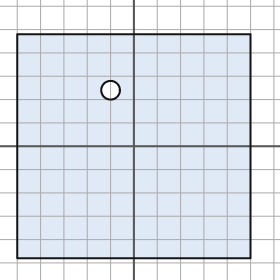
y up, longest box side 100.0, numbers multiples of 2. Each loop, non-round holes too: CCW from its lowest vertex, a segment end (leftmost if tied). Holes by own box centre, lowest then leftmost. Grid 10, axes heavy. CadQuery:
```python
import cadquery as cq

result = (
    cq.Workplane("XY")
    .moveTo(-50.0, -48.0)
    .lineTo(50.0, -48.0)
    .lineTo(50.0, 48.0)
    .lineTo(-50.0, 48.0)
    .close()
    .moveTo(-10.0, 24.0)
    .circle(4.0)
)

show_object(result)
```